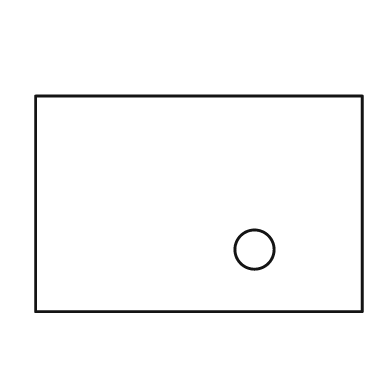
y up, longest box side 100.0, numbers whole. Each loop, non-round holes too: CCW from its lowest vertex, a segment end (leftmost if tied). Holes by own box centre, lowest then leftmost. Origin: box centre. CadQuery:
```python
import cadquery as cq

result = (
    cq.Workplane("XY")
    .moveTo(-50.0, -33.0)
    .lineTo(50.0, -33.0)
    .lineTo(50.0, 33.0)
    .lineTo(-50.0, 33.0)
    .close()
    .moveTo(17.0, -14.0)
    .circle(6.0)
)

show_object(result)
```